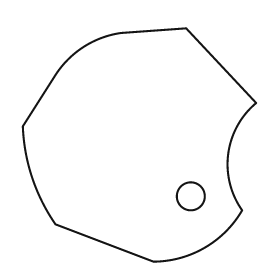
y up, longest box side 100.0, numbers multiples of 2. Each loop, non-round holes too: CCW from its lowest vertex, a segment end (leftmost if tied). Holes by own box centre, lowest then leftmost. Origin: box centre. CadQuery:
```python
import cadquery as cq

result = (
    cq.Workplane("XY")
    .moveTo(6.0, -50.0)
    .threePointArc((28.0, -44.0), (44.0, -28.0))
    .threePointArc((38.0, -4.0), (50.0, 18.0))
    .lineTo(20.0, 50.0)
    .lineTo(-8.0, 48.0)
    .threePointArc((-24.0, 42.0), (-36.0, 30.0))
    .lineTo(-50.0, 8.0)
    .threePointArc((-46.0, -14.0), (-36.0, -34.0))
    .close()
    .moveTo(22.0, -22.0)
    .circle(6.0)
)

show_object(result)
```